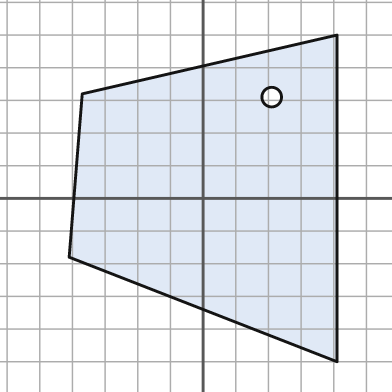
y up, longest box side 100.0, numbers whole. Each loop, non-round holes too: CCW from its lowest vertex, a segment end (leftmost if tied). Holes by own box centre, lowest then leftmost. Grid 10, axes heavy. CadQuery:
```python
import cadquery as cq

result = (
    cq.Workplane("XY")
    .moveTo(41.0, -50.0)
    .lineTo(41.0, 50.0)
    .lineTo(-37.0, 32.0)
    .lineTo(-41.0, -18.0)
    .close()
    .moveTo(21.0, 31.0)
    .circle(3.0)
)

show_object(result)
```